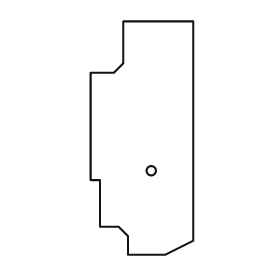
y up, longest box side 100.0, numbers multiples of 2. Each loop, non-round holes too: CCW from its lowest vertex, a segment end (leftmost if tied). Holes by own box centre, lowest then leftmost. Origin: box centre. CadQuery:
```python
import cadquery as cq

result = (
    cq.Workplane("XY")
    .moveTo(-6.0, -50.0)
    .lineTo(10.0, -50.0)
    .lineTo(22.0, -44.0)
    .lineTo(22.0, 50.0)
    .lineTo(-8.0, 50.0)
    .lineTo(-8.0, 32.0)
    .lineTo(-12.0, 28.0)
    .lineTo(-22.0, 28.0)
    .lineTo(-22.0, -18.0)
    .lineTo(-18.0, -18.0)
    .lineTo(-18.0, -38.0)
    .lineTo(-10.0, -38.0)
    .lineTo(-6.0, -42.0)
    .close()
    .moveTo(4.0, -14.0)
    .circle(2.0)
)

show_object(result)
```